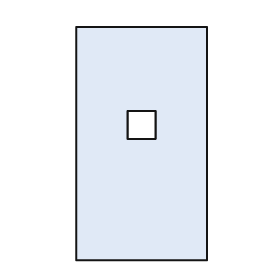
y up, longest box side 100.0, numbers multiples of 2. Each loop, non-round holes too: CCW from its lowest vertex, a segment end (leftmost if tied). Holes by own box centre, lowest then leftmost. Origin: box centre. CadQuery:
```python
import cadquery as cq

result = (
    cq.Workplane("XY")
    .moveTo(-28.0, -50.0)
    .lineTo(28.0, -50.0)
    .lineTo(28.0, 50.0)
    .lineTo(-28.0, 50.0)
    .close()
    .moveTo(-6.0, 2.0)
    .lineTo(6.0, 2.0)
    .lineTo(6.0, 14.0)
    .lineTo(-6.0, 14.0)
    .close()
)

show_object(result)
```